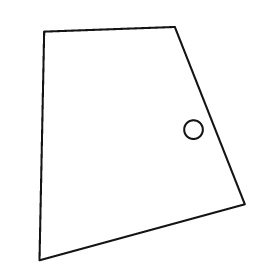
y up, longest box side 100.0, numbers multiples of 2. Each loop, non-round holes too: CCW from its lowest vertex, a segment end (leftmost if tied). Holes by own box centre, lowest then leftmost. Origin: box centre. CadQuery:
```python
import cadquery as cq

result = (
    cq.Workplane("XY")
    .moveTo(-44.0, -50.0)
    .lineTo(44.0, -26.0)
    .lineTo(14.0, 50.0)
    .lineTo(-42.0, 48.0)
    .close()
    .moveTo(22.0, 6.0)
    .circle(4.0)
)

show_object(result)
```